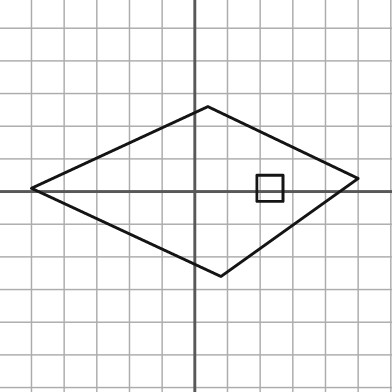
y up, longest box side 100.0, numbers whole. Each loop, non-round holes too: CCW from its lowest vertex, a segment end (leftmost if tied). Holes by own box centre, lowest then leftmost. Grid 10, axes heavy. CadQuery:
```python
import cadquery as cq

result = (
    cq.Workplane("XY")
    .moveTo(8.0, -26.0)
    .lineTo(50.0, 4.0)
    .lineTo(4.0, 26.0)
    .lineTo(-50.0, 1.0)
    .close()
    .moveTo(19.0, -3.0)
    .lineTo(27.0, -3.0)
    .lineTo(27.0, 5.0)
    .lineTo(19.0, 5.0)
    .close()
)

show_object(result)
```